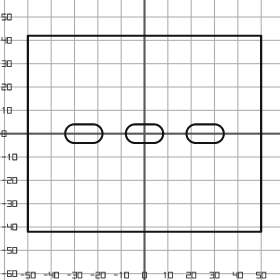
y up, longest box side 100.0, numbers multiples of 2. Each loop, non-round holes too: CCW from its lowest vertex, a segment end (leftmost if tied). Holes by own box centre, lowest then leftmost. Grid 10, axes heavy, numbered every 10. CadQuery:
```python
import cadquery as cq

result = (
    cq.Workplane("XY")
    .moveTo(-50.0, -42.0)
    .lineTo(50.0, -42.0)
    .lineTo(50.0, 42.0)
    .lineTo(-50.0, 42.0)
    .close()
    .moveTo(-30.0, -4.0)
    .lineTo(-22.0, -4.0)
    .threePointArc((-18.0, 0.0), (-22.0, 4.0))
    .lineTo(-30.0, 4.0)
    .threePointArc((-34.0, 0.0), (-30.0, -4.0))
    .close()
    .moveTo(-4.0, -4.0)
    .lineTo(4.0, -4.0)
    .threePointArc((8.0, 0.0), (4.0, 4.0))
    .lineTo(-4.0, 4.0)
    .threePointArc((-8.0, 0.0), (-4.0, -4.0))
    .close()
    .moveTo(22.0, -4.0)
    .lineTo(30.0, -4.0)
    .threePointArc((34.0, 0.0), (30.0, 4.0))
    .lineTo(22.0, 4.0)
    .threePointArc((18.0, 0.0), (22.0, -4.0))
    .close()
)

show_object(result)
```